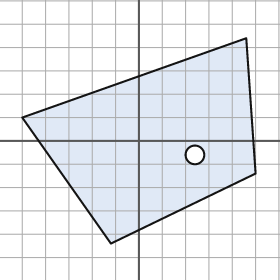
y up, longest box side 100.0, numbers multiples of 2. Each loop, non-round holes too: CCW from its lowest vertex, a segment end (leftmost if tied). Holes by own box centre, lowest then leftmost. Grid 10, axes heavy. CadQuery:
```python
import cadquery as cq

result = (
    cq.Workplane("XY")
    .moveTo(-12.0, -44.0)
    .lineTo(50.0, -14.0)
    .lineTo(46.0, 44.0)
    .lineTo(-50.0, 10.0)
    .close()
    .moveTo(24.0, -6.0)
    .circle(4.0)
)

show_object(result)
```